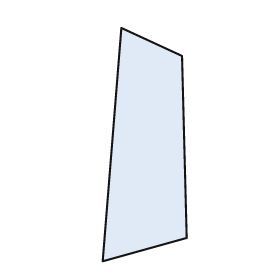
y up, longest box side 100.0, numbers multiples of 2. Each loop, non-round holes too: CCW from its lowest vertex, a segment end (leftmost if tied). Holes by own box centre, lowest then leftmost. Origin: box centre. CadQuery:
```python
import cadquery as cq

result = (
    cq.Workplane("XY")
    .moveTo(-18.0, -50.0)
    .lineTo(18.0, -40.0)
    .lineTo(16.0, 38.0)
    .lineTo(-10.0, 50.0)
    .close()
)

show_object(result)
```